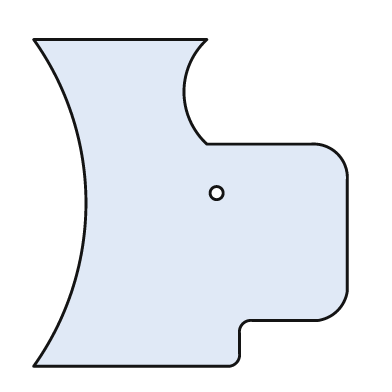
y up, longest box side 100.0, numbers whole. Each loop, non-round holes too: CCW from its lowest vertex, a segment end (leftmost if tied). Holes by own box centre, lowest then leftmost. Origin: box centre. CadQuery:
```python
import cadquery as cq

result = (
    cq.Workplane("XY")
    .moveTo(-48.0, -50.0)
    .lineTo(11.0, -50.0)
    .threePointArc((14.0, -49.0), (15.0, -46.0))
    .lineTo(15.0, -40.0)
    .threePointArc((16.0, -37.0), (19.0, -36.0))
    .lineTo(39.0, -36.0)
    .threePointArc((45.0, -33.0), (48.0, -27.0))
    .lineTo(48.0, 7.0)
    .threePointArc((45.0, 15.0), (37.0, 18.0))
    .lineTo(5.0, 18.0)
    .threePointArc((-2.0, 34.0), (5.0, 50.0))
    .lineTo(-48.0, 50.0)
    .threePointArc((-32.0, 0.0), (-48.0, -50.0))
    .close()
    .moveTo(8.0, 3.0)
    .circle(2.0)
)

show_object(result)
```